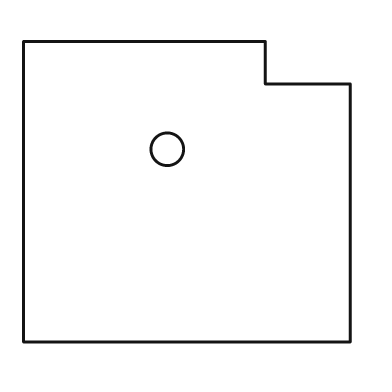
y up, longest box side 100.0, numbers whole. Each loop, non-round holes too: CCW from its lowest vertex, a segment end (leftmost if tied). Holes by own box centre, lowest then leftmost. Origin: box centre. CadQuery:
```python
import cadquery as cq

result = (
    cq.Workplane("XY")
    .moveTo(-50.0, -46.0)
    .lineTo(50.0, -46.0)
    .lineTo(50.0, 33.0)
    .lineTo(24.0, 33.0)
    .lineTo(24.0, 46.0)
    .lineTo(-50.0, 46.0)
    .close()
    .moveTo(-6.0, 13.0)
    .circle(5.0)
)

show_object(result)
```